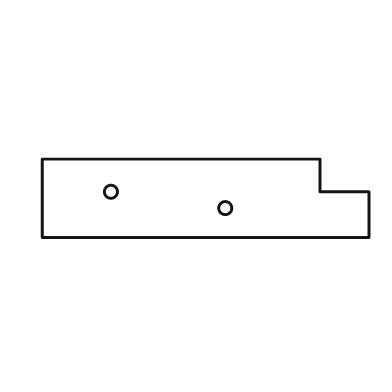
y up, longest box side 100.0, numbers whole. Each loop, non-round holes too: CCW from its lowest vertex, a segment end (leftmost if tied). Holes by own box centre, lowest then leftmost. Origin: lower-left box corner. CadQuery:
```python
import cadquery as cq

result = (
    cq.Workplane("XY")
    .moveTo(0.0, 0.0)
    .lineTo(100.0, 0.0)
    .lineTo(100.0, 14.0)
    .lineTo(85.0, 14.0)
    .lineTo(85.0, 24.0)
    .lineTo(0.0, 24.0)
    .close()
    .moveTo(56.0, 9.0)
    .circle(2.0)
    .moveTo(21.0, 14.0)
    .circle(2.0)
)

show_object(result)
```